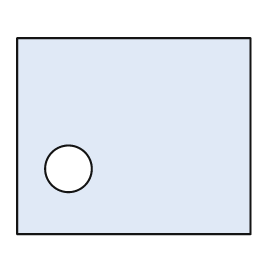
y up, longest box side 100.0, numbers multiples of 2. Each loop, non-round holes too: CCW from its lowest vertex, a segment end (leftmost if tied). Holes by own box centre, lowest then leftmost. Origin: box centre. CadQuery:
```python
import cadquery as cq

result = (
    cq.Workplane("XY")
    .moveTo(-50.0, -42.0)
    .lineTo(50.0, -42.0)
    .lineTo(50.0, 42.0)
    .lineTo(-50.0, 42.0)
    .close()
    .moveTo(-28.0, -14.0)
    .circle(10.0)
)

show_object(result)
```